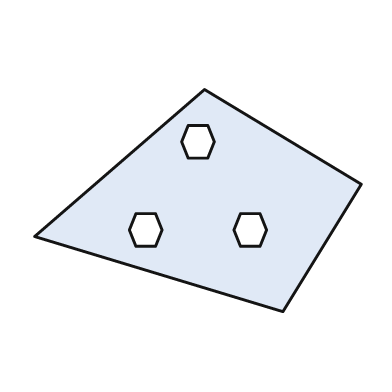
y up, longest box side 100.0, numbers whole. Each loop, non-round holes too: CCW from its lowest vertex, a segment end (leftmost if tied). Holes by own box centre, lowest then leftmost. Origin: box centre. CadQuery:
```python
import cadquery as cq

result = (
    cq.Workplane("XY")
    .moveTo(26.0, -34.0)
    .lineTo(50.0, 5.0)
    .lineTo(2.0, 34.0)
    .lineTo(-50.0, -11.0)
    .close()
    .moveTo(-19.0, -14.0)
    .lineTo(-13.0, -14.0)
    .lineTo(-11.0, -9.0)
    .lineTo(-13.0, -4.0)
    .lineTo(-19.0, -4.0)
    .lineTo(-21.0, -9.0)
    .close()
    .moveTo(13.0, -14.0)
    .lineTo(19.0, -14.0)
    .lineTo(21.0, -9.0)
    .lineTo(19.0, -4.0)
    .lineTo(13.0, -4.0)
    .lineTo(11.0, -9.0)
    .close()
    .moveTo(-3.0, 13.0)
    .lineTo(3.0, 13.0)
    .lineTo(5.0, 18.0)
    .lineTo(3.0, 23.0)
    .lineTo(-3.0, 23.0)
    .lineTo(-5.0, 18.0)
    .close()
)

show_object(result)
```